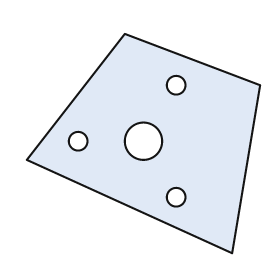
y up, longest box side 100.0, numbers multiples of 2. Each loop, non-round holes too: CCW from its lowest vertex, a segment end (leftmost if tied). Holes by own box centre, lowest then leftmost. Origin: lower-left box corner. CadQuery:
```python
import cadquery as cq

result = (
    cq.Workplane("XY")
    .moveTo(88.0, 0.0)
    .lineTo(100.0, 72.0)
    .lineTo(42.0, 94.0)
    .lineTo(0.0, 40.0)
    .close()
    .moveTo(64.0, 24.0)
    .circle(4.0)
    .moveTo(22.0, 48.0)
    .circle(4.0)
    .moveTo(50.0, 48.0)
    .circle(8.0)
    .moveTo(64.0, 72.0)
    .circle(4.0)
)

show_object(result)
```